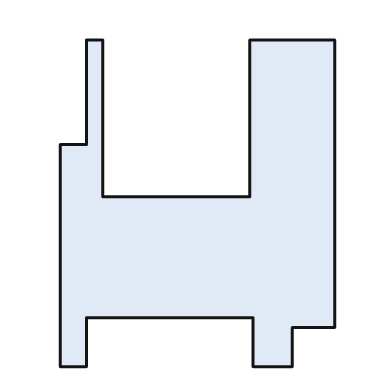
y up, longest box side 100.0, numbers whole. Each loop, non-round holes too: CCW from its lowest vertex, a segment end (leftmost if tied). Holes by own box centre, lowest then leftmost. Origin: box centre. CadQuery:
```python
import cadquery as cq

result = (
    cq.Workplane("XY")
    .moveTo(-42.0, -50.0)
    .lineTo(-34.0, -50.0)
    .lineTo(-34.0, -35.0)
    .lineTo(17.0, -35.0)
    .lineTo(17.0, -50.0)
    .lineTo(29.0, -50.0)
    .lineTo(29.0, -38.0)
    .lineTo(42.0, -38.0)
    .lineTo(42.0, 50.0)
    .lineTo(16.0, 50.0)
    .lineTo(16.0, 2.0)
    .lineTo(-29.0, 2.0)
    .lineTo(-29.0, 50.0)
    .lineTo(-34.0, 50.0)
    .lineTo(-34.0, 18.0)
    .lineTo(-42.0, 18.0)
    .close()
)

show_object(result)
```